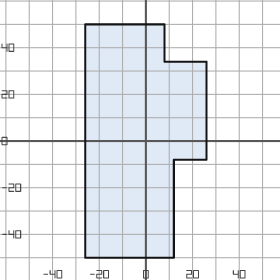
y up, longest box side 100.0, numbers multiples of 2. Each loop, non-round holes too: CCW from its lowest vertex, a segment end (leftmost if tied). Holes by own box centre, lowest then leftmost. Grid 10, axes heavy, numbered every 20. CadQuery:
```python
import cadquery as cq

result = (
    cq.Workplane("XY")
    .moveTo(-26.0, -50.0)
    .lineTo(12.0, -50.0)
    .lineTo(12.0, -8.0)
    .lineTo(26.0, -8.0)
    .lineTo(26.0, 34.0)
    .lineTo(8.0, 34.0)
    .lineTo(8.0, 50.0)
    .lineTo(-26.0, 50.0)
    .close()
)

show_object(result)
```